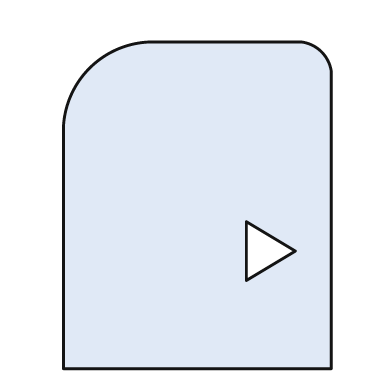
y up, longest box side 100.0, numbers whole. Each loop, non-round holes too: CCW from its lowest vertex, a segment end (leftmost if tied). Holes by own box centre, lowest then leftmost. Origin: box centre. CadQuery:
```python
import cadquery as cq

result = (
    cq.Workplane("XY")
    .moveTo(-41.0, -50.0)
    .lineTo(41.0, -50.0)
    .lineTo(41.0, 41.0)
    .threePointArc((38.0, 47.0), (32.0, 50.0))
    .lineTo(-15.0, 50.0)
    .threePointArc((-33.0, 42.0), (-41.0, 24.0))
    .close()
    .moveTo(15.0, -23.0)
    .lineTo(30.0, -14.0)
    .lineTo(15.0, -5.0)
    .close()
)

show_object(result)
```